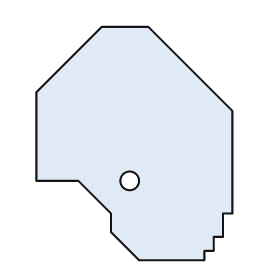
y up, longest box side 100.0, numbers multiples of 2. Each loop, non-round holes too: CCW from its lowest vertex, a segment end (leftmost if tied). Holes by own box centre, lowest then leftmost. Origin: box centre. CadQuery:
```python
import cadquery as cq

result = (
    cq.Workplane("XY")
    .moveTo(2.0, -50.0)
    .lineTo(30.0, -50.0)
    .lineTo(30.0, -46.0)
    .lineTo(34.0, -46.0)
    .lineTo(34.0, -40.0)
    .lineTo(38.0, -40.0)
    .lineTo(38.0, -30.0)
    .lineTo(42.0, -30.0)
    .lineTo(42.0, 14.0)
    .lineTo(6.0, 50.0)
    .lineTo(-14.0, 50.0)
    .lineTo(-42.0, 22.0)
    .lineTo(-42.0, -16.0)
    .lineTo(-24.0, -16.0)
    .lineTo(-10.0, -30.0)
    .lineTo(-10.0, -38.0)
    .close()
    .moveTo(-2.0, -16.0)
    .circle(4.0)
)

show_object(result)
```